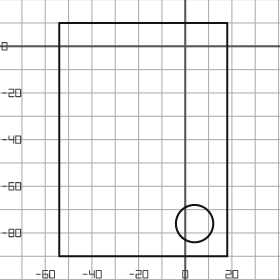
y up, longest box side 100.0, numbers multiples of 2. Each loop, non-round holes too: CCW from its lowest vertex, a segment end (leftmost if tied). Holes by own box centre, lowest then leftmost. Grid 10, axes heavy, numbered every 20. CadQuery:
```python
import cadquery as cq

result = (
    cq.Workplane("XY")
    .moveTo(-54.0, -90.0)
    .lineTo(18.0, -90.0)
    .lineTo(18.0, 10.0)
    .lineTo(-54.0, 10.0)
    .close()
    .moveTo(4.0, -76.0)
    .circle(8.0)
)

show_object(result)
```